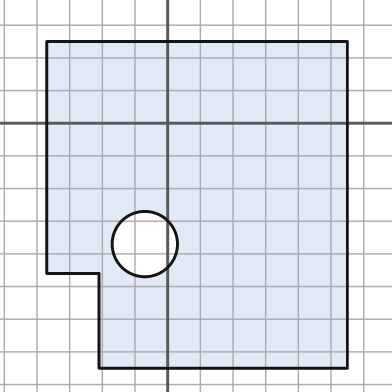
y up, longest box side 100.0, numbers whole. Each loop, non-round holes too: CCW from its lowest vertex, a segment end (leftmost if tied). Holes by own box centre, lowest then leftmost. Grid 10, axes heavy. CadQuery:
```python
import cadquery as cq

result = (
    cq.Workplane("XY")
    .moveTo(-21.0, -75.0)
    .lineTo(55.0, -75.0)
    .lineTo(55.0, 25.0)
    .lineTo(-37.0, 25.0)
    .lineTo(-37.0, -46.0)
    .lineTo(-21.0, -46.0)
    .close()
    .moveTo(-7.0, -37.0)
    .circle(10.0)
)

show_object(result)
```